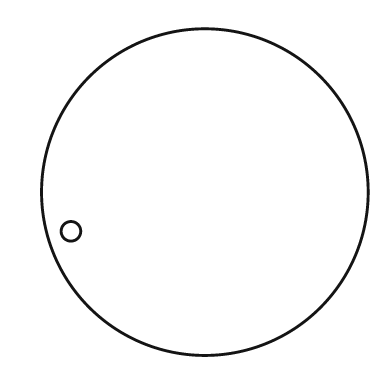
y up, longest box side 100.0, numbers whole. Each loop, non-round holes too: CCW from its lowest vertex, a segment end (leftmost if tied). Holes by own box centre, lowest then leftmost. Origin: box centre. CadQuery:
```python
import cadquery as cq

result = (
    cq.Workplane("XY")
    .moveTo(0.0, 0.0)
    .circle(50.0)
    .moveTo(-41.0, -12.0)
    .circle(3.0)
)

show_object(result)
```